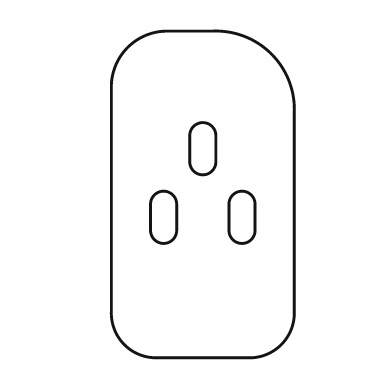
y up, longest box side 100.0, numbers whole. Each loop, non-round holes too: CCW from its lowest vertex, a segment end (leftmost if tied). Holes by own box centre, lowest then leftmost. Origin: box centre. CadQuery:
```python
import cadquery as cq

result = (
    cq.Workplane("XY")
    .moveTo(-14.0, -50.0)
    .lineTo(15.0, -50.0)
    .threePointArc((24.0, -46.0), (28.0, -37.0))
    .lineTo(28.0, 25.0)
    .threePointArc((21.0, 43.0), (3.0, 50.0))
    .lineTo(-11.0, 50.0)
    .threePointArc((-23.0, 45.0), (-28.0, 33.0))
    .lineTo(-28.0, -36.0)
    .threePointArc((-24.0, -46.0), (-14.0, -50.0))
    .close()
    .moveTo(-16.0, -11.0)
    .threePointArc((-12.0, -15.0), (-8.0, -11.0))
    .lineTo(-8.0, -3.0)
    .threePointArc((-12.0, 1.0), (-16.0, -3.0))
    .close()
    .moveTo(8.0, -11.0)
    .threePointArc((12.0, -15.0), (16.0, -11.0))
    .lineTo(16.0, -3.0)
    .threePointArc((12.0, 1.0), (8.0, -3.0))
    .close()
    .moveTo(-4.0, 10.0)
    .threePointArc((0.0, 6.0), (4.0, 10.0))
    .lineTo(4.0, 18.0)
    .threePointArc((0.0, 22.0), (-4.0, 18.0))
    .close()
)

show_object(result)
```